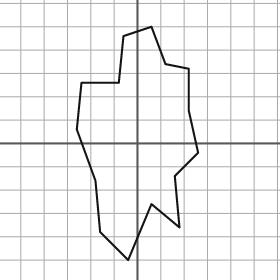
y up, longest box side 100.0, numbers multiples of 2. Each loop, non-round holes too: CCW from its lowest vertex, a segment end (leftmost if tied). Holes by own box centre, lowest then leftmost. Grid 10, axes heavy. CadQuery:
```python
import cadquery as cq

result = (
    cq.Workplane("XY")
    .moveTo(-4.0, -50.0)
    .lineTo(6.0, -26.0)
    .lineTo(18.0, -36.0)
    .lineTo(16.0, -14.0)
    .lineTo(26.0, -4.0)
    .lineTo(22.0, 14.0)
    .lineTo(22.0, 32.0)
    .lineTo(12.0, 34.0)
    .lineTo(6.0, 50.0)
    .lineTo(-6.0, 46.0)
    .lineTo(-8.0, 26.0)
    .lineTo(-24.0, 26.0)
    .lineTo(-26.0, 6.0)
    .lineTo(-18.0, -16.0)
    .lineTo(-16.0, -38.0)
    .close()
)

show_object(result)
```